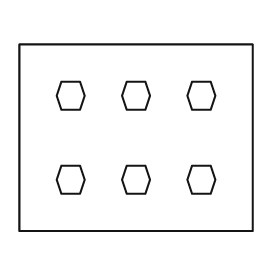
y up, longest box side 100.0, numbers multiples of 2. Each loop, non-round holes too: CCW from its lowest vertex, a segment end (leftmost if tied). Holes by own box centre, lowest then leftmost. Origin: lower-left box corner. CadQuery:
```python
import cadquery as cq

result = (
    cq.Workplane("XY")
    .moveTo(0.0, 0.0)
    .lineTo(100.0, 0.0)
    .lineTo(100.0, 80.0)
    .lineTo(0.0, 80.0)
    .close()
    .moveTo(18.0, 16.0)
    .lineTo(26.0, 16.0)
    .lineTo(28.0, 22.0)
    .lineTo(26.0, 28.0)
    .lineTo(18.0, 28.0)
    .lineTo(16.0, 22.0)
    .close()
    .moveTo(46.0, 16.0)
    .lineTo(54.0, 16.0)
    .lineTo(56.0, 22.0)
    .lineTo(54.0, 28.0)
    .lineTo(46.0, 28.0)
    .lineTo(44.0, 22.0)
    .close()
    .moveTo(74.0, 16.0)
    .lineTo(82.0, 16.0)
    .lineTo(84.0, 22.0)
    .lineTo(82.0, 28.0)
    .lineTo(74.0, 28.0)
    .lineTo(72.0, 22.0)
    .close()
    .moveTo(18.0, 52.0)
    .lineTo(26.0, 52.0)
    .lineTo(28.0, 58.0)
    .lineTo(26.0, 64.0)
    .lineTo(18.0, 64.0)
    .lineTo(16.0, 58.0)
    .close()
    .moveTo(46.0, 52.0)
    .lineTo(54.0, 52.0)
    .lineTo(56.0, 58.0)
    .lineTo(54.0, 64.0)
    .lineTo(46.0, 64.0)
    .lineTo(44.0, 58.0)
    .close()
    .moveTo(74.0, 52.0)
    .lineTo(82.0, 52.0)
    .lineTo(84.0, 58.0)
    .lineTo(82.0, 64.0)
    .lineTo(74.0, 64.0)
    .lineTo(72.0, 58.0)
    .close()
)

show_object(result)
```